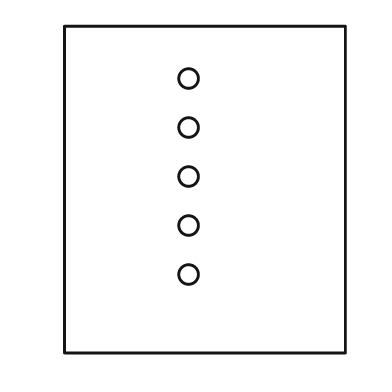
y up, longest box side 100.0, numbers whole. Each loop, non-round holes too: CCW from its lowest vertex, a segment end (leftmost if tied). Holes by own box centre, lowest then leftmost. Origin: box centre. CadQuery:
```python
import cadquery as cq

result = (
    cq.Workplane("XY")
    .moveTo(-43.0, -50.0)
    .lineTo(43.0, -50.0)
    .lineTo(43.0, 50.0)
    .lineTo(-43.0, 50.0)
    .close()
    .moveTo(-5.0, -26.0)
    .circle(3.0)
    .moveTo(-5.0, -11.0)
    .circle(3.0)
    .moveTo(-5.0, 4.0)
    .circle(3.0)
    .moveTo(-5.0, 19.0)
    .circle(3.0)
    .moveTo(-5.0, 34.0)
    .circle(3.0)
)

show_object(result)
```